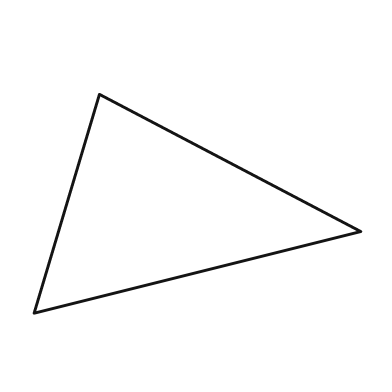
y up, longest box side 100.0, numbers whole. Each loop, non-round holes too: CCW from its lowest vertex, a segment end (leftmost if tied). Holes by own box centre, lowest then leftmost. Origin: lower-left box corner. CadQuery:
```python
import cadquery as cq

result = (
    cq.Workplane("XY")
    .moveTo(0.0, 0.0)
    .lineTo(100.0, 25.0)
    .lineTo(20.0, 67.0)
    .close()
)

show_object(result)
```